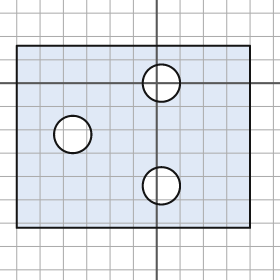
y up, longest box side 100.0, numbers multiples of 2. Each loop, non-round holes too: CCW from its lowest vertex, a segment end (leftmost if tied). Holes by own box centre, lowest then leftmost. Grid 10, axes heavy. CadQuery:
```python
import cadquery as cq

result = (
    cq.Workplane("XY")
    .moveTo(-60.0, -62.0)
    .lineTo(40.0, -62.0)
    .lineTo(40.0, 16.0)
    .lineTo(-60.0, 16.0)
    .close()
    .moveTo(2.0, -44.0)
    .circle(8.0)
    .moveTo(-36.0, -22.0)
    .circle(8.0)
    .moveTo(2.0, 0.0)
    .circle(8.0)
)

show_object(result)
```